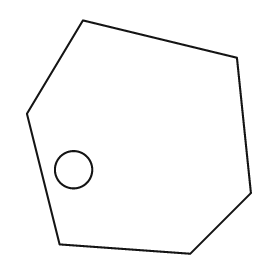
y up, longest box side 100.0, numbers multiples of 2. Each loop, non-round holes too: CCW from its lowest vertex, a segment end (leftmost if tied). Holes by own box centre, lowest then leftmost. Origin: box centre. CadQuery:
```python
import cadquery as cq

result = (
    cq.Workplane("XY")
    .moveTo(22.0, -50.0)
    .lineTo(48.0, -24.0)
    .lineTo(42.0, 34.0)
    .lineTo(-24.0, 50.0)
    .lineTo(-48.0, 10.0)
    .lineTo(-34.0, -46.0)
    .close()
    .moveTo(-28.0, -14.0)
    .circle(8.0)
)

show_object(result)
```